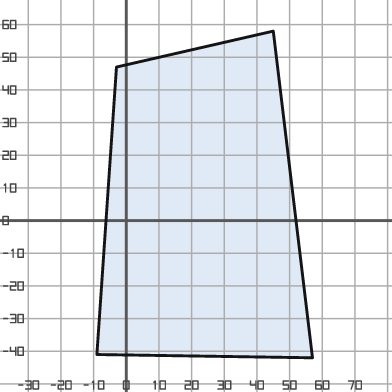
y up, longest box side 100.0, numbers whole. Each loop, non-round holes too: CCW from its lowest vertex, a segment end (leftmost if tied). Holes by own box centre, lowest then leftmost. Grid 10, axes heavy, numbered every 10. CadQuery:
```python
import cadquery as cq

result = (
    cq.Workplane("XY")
    .moveTo(57.0, -42.0)
    .lineTo(45.0, 58.0)
    .lineTo(-3.0, 47.0)
    .lineTo(-9.0, -41.0)
    .close()
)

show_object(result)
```